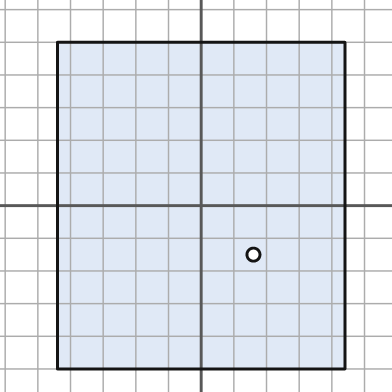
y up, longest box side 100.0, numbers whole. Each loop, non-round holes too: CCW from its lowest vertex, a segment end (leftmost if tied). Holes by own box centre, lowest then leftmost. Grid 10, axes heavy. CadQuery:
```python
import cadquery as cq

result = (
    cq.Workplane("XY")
    .moveTo(-44.0, -50.0)
    .lineTo(44.0, -50.0)
    .lineTo(44.0, 50.0)
    .lineTo(-44.0, 50.0)
    .close()
    .moveTo(16.0, -15.0)
    .circle(2.0)
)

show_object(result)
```